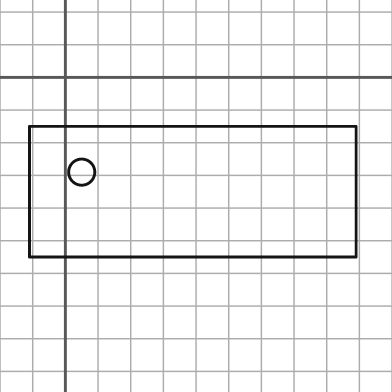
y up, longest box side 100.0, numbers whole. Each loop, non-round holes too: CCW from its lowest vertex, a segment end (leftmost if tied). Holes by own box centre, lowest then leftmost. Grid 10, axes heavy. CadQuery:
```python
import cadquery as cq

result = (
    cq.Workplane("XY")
    .moveTo(-11.0, -55.0)
    .lineTo(89.0, -55.0)
    .lineTo(89.0, -15.0)
    .lineTo(-11.0, -15.0)
    .close()
    .moveTo(5.0, -29.0)
    .circle(4.0)
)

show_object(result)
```